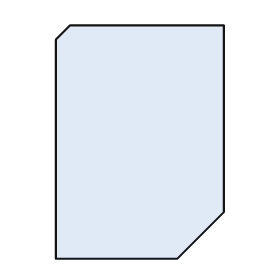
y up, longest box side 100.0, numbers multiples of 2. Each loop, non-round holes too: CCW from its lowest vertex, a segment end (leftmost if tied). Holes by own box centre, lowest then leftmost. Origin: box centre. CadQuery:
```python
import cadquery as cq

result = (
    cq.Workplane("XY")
    .moveTo(-36.0, -50.0)
    .lineTo(16.0, -50.0)
    .lineTo(36.0, -30.0)
    .lineTo(36.0, 50.0)
    .lineTo(-30.0, 50.0)
    .lineTo(-36.0, 44.0)
    .close()
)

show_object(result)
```